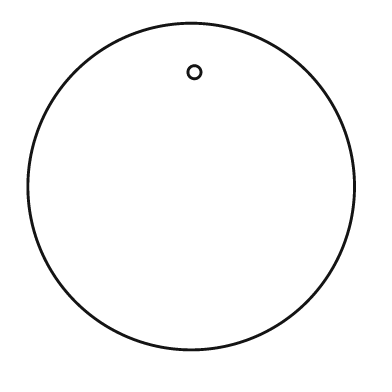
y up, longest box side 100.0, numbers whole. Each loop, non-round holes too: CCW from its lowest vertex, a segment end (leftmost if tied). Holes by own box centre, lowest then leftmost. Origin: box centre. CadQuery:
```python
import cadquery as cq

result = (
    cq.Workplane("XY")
    .moveTo(0.0, 0.0)
    .circle(50.0)
    .moveTo(1.0, 35.0)
    .circle(2.0)
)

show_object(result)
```